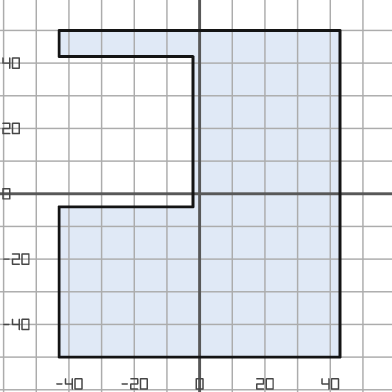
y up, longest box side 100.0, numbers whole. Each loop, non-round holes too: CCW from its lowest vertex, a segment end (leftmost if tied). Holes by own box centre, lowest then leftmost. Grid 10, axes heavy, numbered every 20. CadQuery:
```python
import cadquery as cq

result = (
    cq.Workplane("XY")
    .moveTo(-43.0, -50.0)
    .lineTo(43.0, -50.0)
    .lineTo(43.0, 50.0)
    .lineTo(-43.0, 50.0)
    .lineTo(-43.0, 42.0)
    .lineTo(-2.0, 42.0)
    .lineTo(-2.0, -4.0)
    .lineTo(-43.0, -4.0)
    .close()
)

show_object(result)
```